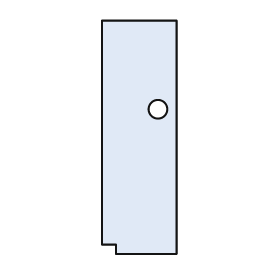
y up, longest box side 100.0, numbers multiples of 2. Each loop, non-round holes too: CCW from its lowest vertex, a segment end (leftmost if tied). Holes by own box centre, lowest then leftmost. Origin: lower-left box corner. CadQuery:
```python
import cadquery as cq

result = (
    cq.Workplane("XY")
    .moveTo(6.0, 0.0)
    .lineTo(32.0, 0.0)
    .lineTo(32.0, 100.0)
    .lineTo(0.0, 100.0)
    .lineTo(0.0, 4.0)
    .lineTo(6.0, 4.0)
    .close()
    .moveTo(24.0, 62.0)
    .circle(4.0)
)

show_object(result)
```